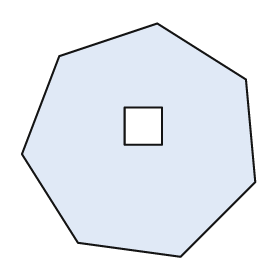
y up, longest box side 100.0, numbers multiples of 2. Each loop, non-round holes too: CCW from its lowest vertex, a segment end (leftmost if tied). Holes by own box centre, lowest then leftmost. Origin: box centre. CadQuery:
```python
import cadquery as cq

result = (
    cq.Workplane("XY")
    .moveTo(18.0, -50.0)
    .lineTo(50.0, -18.0)
    .lineTo(46.0, 26.0)
    .lineTo(8.0, 50.0)
    .lineTo(-34.0, 36.0)
    .lineTo(-50.0, -6.0)
    .lineTo(-26.0, -44.0)
    .close()
    .moveTo(-6.0, -2.0)
    .lineTo(10.0, -2.0)
    .lineTo(10.0, 14.0)
    .lineTo(-6.0, 14.0)
    .close()
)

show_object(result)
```